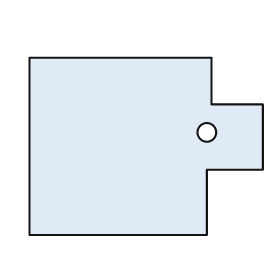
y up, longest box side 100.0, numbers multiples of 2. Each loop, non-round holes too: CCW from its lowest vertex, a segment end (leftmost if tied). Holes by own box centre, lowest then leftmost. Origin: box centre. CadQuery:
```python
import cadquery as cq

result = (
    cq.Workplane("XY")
    .moveTo(-50.0, -38.0)
    .lineTo(26.0, -38.0)
    .lineTo(26.0, -10.0)
    .lineTo(50.0, -10.0)
    .lineTo(50.0, 18.0)
    .lineTo(28.0, 18.0)
    .lineTo(28.0, 38.0)
    .lineTo(-50.0, 38.0)
    .close()
    .moveTo(26.0, 6.0)
    .circle(4.0)
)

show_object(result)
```